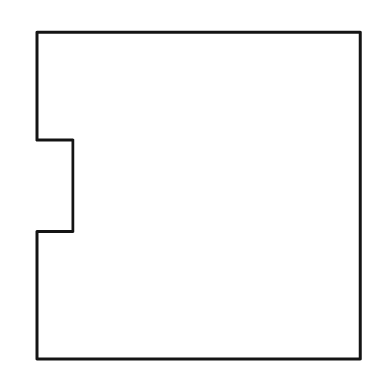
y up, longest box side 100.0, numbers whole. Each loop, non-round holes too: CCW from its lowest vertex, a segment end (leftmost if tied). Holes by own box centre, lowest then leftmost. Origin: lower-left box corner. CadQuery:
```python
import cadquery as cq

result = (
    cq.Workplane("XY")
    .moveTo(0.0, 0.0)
    .lineTo(99.0, 0.0)
    .lineTo(99.0, 100.0)
    .lineTo(0.0, 100.0)
    .lineTo(0.0, 67.0)
    .lineTo(11.0, 67.0)
    .lineTo(11.0, 39.0)
    .lineTo(0.0, 39.0)
    .close()
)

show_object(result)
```